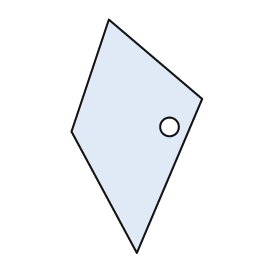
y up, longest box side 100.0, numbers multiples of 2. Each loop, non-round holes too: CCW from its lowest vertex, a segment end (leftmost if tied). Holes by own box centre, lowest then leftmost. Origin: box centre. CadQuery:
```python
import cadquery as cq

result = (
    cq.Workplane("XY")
    .moveTo(0.0, -50.0)
    .lineTo(28.0, 16.0)
    .lineTo(-12.0, 50.0)
    .lineTo(-28.0, 2.0)
    .close()
    .moveTo(14.0, 4.0)
    .circle(4.0)
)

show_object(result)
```